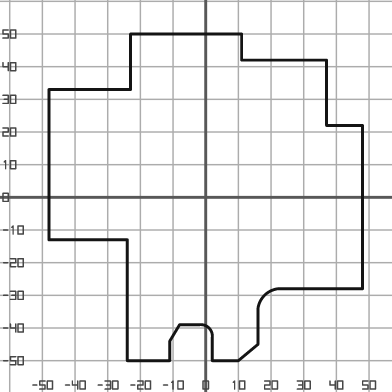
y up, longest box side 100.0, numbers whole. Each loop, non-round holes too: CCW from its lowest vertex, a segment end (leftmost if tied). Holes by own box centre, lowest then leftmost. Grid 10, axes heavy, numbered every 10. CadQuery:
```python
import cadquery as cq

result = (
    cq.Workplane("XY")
    .moveTo(-24.0, -50.0)
    .lineTo(-11.0, -50.0)
    .lineTo(-11.0, -44.0)
    .lineTo(-8.0, -39.0)
    .lineTo(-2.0, -39.0)
    .threePointArc((1.0, -40.0), (2.0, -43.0))
    .lineTo(2.0, -50.0)
    .lineTo(10.0, -50.0)
    .lineTo(16.0, -45.0)
    .lineTo(16.0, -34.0)
    .threePointArc((18.0, -30.0), (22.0, -28.0))
    .lineTo(48.0, -28.0)
    .lineTo(48.0, 22.0)
    .lineTo(37.0, 22.0)
    .lineTo(37.0, 42.0)
    .lineTo(11.0, 42.0)
    .lineTo(11.0, 50.0)
    .lineTo(-23.0, 50.0)
    .lineTo(-23.0, 33.0)
    .lineTo(-48.0, 33.0)
    .lineTo(-48.0, -13.0)
    .lineTo(-24.0, -13.0)
    .close()
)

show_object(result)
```